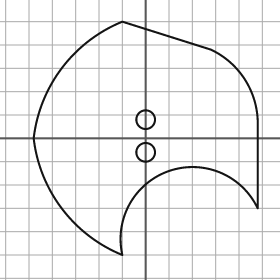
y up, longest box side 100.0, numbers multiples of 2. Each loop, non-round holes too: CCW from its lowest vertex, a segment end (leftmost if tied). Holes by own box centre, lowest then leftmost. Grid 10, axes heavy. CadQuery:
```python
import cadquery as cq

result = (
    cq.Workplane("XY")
    .moveTo(-10.0, -50.0)
    .threePointArc((10.0, -14.0), (48.0, -30.0))
    .lineTo(48.0, 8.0)
    .threePointArc((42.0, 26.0), (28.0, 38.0))
    .lineTo(-10.0, 50.0)
    .threePointArc((-36.0, 30.0), (-48.0, 0.0))
    .threePointArc((-36.0, -30.0), (-10.0, -50.0))
    .close()
    .moveTo(0.0, -6.0)
    .circle(4.0)
    .moveTo(0.0, 8.0)
    .circle(4.0)
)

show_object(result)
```